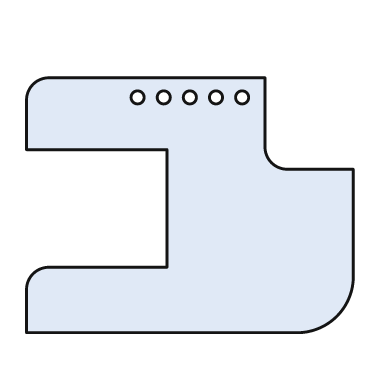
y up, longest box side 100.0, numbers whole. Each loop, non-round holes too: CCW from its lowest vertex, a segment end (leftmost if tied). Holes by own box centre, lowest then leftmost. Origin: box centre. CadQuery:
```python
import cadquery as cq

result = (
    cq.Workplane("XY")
    .moveTo(-50.0, -39.0)
    .lineTo(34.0, -39.0)
    .threePointArc((45.0, -34.0), (50.0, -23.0))
    .lineTo(50.0, 11.0)
    .lineTo(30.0, 11.0)
    .threePointArc((25.0, 13.0), (23.0, 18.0))
    .lineTo(23.0, 39.0)
    .lineTo(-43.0, 39.0)
    .threePointArc((-48.0, 37.0), (-50.0, 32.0))
    .lineTo(-50.0, 17.0)
    .lineTo(-7.0, 17.0)
    .lineTo(-7.0, -19.0)
    .lineTo(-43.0, -19.0)
    .threePointArc((-48.0, -21.0), (-50.0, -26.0))
    .close()
    .moveTo(-16.0, 33.0)
    .circle(2.0)
    .moveTo(-8.0, 33.0)
    .circle(2.0)
    .moveTo(0.0, 33.0)
    .circle(2.0)
    .moveTo(8.0, 33.0)
    .circle(2.0)
    .moveTo(16.0, 33.0)
    .circle(2.0)
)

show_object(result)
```